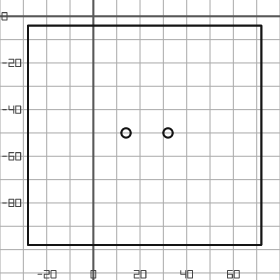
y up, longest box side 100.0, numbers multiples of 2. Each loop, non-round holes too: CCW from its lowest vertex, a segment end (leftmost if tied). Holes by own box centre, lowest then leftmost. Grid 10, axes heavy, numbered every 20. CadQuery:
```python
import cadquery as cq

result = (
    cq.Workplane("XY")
    .moveTo(-28.0, -98.0)
    .lineTo(72.0, -98.0)
    .lineTo(72.0, -4.0)
    .lineTo(-28.0, -4.0)
    .close()
    .moveTo(14.0, -50.0)
    .circle(2.0)
    .moveTo(32.0, -50.0)
    .circle(2.0)
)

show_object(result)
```